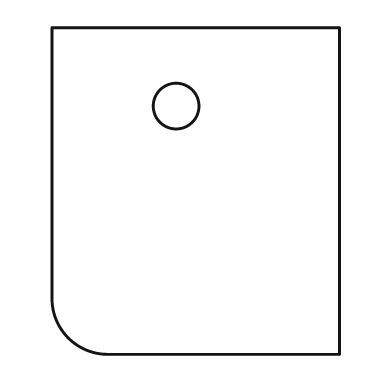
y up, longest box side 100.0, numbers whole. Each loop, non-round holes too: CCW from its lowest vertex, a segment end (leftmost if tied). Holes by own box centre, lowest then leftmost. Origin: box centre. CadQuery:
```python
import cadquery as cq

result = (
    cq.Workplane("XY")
    .moveTo(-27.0, -50.0)
    .lineTo(44.0, -50.0)
    .lineTo(44.0, 50.0)
    .lineTo(-44.0, 50.0)
    .lineTo(-44.0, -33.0)
    .threePointArc((-39.0, -45.0), (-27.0, -50.0))
    .close()
    .moveTo(-6.0, 26.0)
    .circle(7.0)
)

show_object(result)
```